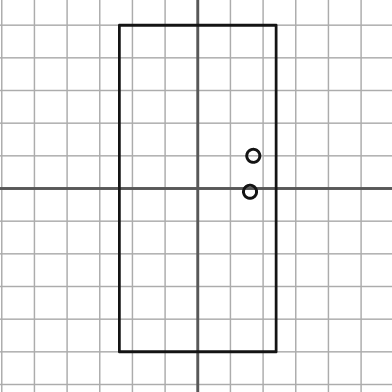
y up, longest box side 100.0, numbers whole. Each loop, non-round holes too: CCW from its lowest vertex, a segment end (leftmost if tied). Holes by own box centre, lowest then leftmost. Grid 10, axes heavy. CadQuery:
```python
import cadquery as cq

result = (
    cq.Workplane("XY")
    .moveTo(-24.0, -50.0)
    .lineTo(24.0, -50.0)
    .lineTo(24.0, 50.0)
    .lineTo(-24.0, 50.0)
    .close()
    .moveTo(16.0, -1.0)
    .circle(2.0)
    .moveTo(17.0, 10.0)
    .circle(2.0)
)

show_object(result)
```